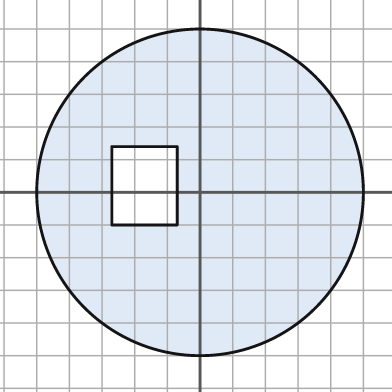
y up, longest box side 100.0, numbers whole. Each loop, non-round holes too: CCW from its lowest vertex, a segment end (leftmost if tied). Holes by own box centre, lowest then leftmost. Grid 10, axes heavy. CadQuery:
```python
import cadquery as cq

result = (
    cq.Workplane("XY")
    .moveTo(0.0, 0.0)
    .circle(50.0)
    .moveTo(-27.0, -10.0)
    .lineTo(-7.0, -10.0)
    .lineTo(-7.0, 14.0)
    .lineTo(-27.0, 14.0)
    .close()
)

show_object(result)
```